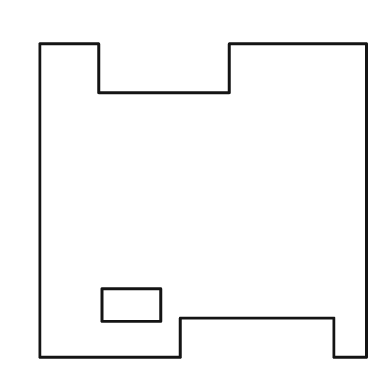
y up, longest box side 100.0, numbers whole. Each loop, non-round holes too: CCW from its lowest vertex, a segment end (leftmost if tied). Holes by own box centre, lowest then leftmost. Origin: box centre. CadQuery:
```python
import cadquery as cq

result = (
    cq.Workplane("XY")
    .moveTo(-50.0, -48.0)
    .lineTo(-7.0, -48.0)
    .lineTo(-7.0, -36.0)
    .lineTo(40.0, -36.0)
    .lineTo(40.0, -48.0)
    .lineTo(50.0, -48.0)
    .lineTo(50.0, 48.0)
    .lineTo(8.0, 48.0)
    .lineTo(8.0, 33.0)
    .lineTo(-32.0, 33.0)
    .lineTo(-32.0, 48.0)
    .lineTo(-50.0, 48.0)
    .close()
    .moveTo(-31.0, -37.0)
    .lineTo(-13.0, -37.0)
    .lineTo(-13.0, -27.0)
    .lineTo(-31.0, -27.0)
    .close()
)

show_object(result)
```